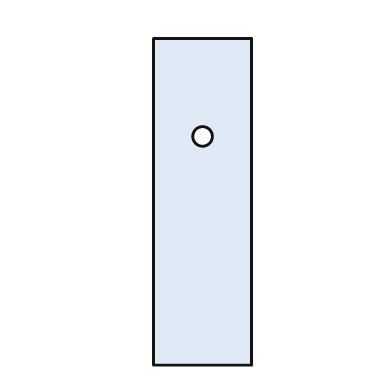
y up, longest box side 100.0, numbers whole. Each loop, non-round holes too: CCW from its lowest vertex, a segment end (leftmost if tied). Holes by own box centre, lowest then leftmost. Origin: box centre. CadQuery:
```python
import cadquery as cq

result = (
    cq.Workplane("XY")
    .moveTo(-15.0, -50.0)
    .lineTo(15.0, -50.0)
    .lineTo(15.0, 50.0)
    .lineTo(-15.0, 50.0)
    .close()
    .moveTo(0.0, 20.0)
    .circle(3.0)
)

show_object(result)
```